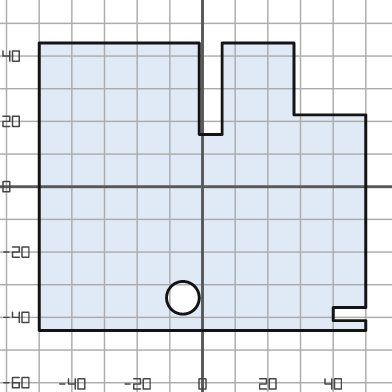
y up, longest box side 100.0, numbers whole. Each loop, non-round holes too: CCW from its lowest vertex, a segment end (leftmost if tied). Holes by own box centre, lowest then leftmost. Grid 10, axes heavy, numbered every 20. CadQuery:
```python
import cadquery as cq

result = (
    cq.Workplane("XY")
    .moveTo(-50.0, -44.0)
    .lineTo(50.0, -44.0)
    .lineTo(50.0, -41.0)
    .lineTo(40.0, -41.0)
    .lineTo(40.0, -37.0)
    .lineTo(50.0, -37.0)
    .lineTo(50.0, 22.0)
    .lineTo(28.0, 22.0)
    .lineTo(28.0, 44.0)
    .lineTo(6.0, 44.0)
    .lineTo(6.0, 16.0)
    .lineTo(-1.0, 16.0)
    .lineTo(-1.0, 44.0)
    .lineTo(-50.0, 44.0)
    .close()
    .moveTo(-6.0, -34.0)
    .circle(5.0)
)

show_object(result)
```